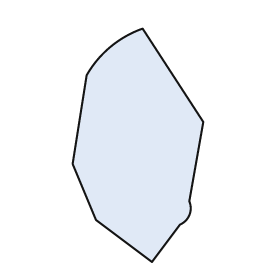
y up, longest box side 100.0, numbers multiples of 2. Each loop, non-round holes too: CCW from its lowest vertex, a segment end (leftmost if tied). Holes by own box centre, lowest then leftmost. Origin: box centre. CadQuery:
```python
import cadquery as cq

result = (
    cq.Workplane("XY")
    .moveTo(6.0, -50.0)
    .lineTo(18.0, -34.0)
    .threePointArc((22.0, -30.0), (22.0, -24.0))
    .lineTo(28.0, 10.0)
    .lineTo(2.0, 50.0)
    .threePointArc((-12.0, 42.0), (-22.0, 30.0))
    .lineTo(-28.0, -8.0)
    .lineTo(-18.0, -32.0)
    .close()
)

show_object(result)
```